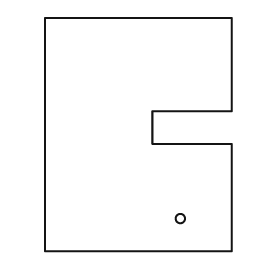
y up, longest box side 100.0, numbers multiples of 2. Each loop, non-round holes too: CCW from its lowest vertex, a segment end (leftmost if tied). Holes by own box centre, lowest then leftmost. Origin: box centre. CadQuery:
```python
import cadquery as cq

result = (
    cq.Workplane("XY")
    .moveTo(-40.0, -50.0)
    .lineTo(40.0, -50.0)
    .lineTo(40.0, -4.0)
    .lineTo(6.0, -4.0)
    .lineTo(6.0, 10.0)
    .lineTo(40.0, 10.0)
    .lineTo(40.0, 50.0)
    .lineTo(-40.0, 50.0)
    .close()
    .moveTo(18.0, -36.0)
    .circle(2.0)
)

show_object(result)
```